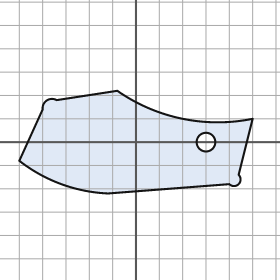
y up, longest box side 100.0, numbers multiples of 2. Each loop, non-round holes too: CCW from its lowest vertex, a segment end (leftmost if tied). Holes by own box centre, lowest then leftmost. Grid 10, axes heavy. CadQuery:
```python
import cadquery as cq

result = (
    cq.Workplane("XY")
    .moveTo(-12.0, -22.0)
    .lineTo(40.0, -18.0)
    .threePointArc((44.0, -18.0), (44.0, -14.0))
    .lineTo(50.0, 10.0)
    .threePointArc((20.0, 10.0), (-8.0, 22.0))
    .lineTo(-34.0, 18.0)
    .threePointArc((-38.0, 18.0), (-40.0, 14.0))
    .lineTo(-50.0, -8.0)
    .threePointArc((-32.0, -18.0), (-12.0, -22.0))
    .close()
    .moveTo(30.0, 0.0)
    .circle(4.0)
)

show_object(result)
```